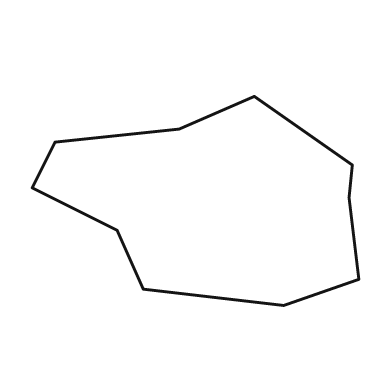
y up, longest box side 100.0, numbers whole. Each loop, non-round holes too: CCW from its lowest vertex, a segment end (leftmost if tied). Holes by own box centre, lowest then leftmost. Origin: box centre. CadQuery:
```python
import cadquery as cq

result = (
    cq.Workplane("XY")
    .moveTo(27.0, -32.0)
    .lineTo(50.0, -24.0)
    .lineTo(47.0, 1.0)
    .lineTo(48.0, 11.0)
    .lineTo(18.0, 32.0)
    .lineTo(-5.0, 22.0)
    .lineTo(-43.0, 18.0)
    .lineTo(-50.0, 4.0)
    .lineTo(-24.0, -9.0)
    .lineTo(-16.0, -27.0)
    .close()
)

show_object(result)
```